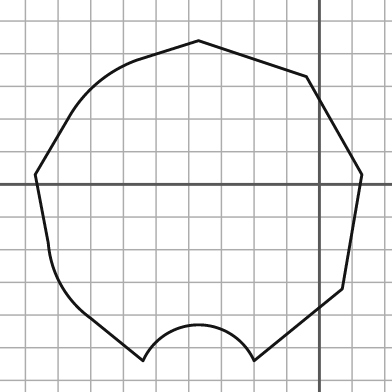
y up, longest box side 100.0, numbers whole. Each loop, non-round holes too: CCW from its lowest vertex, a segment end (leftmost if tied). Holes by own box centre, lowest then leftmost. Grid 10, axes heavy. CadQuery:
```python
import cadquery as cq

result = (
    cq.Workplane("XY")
    .moveTo(-54.0, -54.0)
    .threePointArc((-37.0, -43.0), (-20.0, -54.0))
    .lineTo(7.0, -32.0)
    .lineTo(13.0, 3.0)
    .lineTo(-4.0, 33.0)
    .lineTo(-37.0, 44.0)
    .lineTo(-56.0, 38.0)
    .threePointArc((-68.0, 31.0), (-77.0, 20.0))
    .lineTo(-87.0, 3.0)
    .lineTo(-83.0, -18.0)
    .threePointArc((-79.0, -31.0), (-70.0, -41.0))
    .close()
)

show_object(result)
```